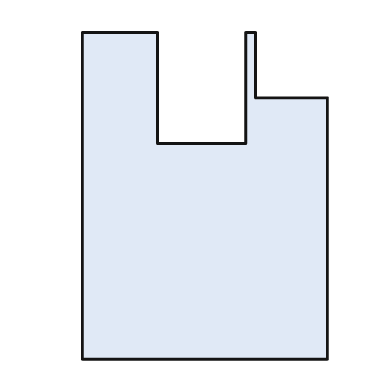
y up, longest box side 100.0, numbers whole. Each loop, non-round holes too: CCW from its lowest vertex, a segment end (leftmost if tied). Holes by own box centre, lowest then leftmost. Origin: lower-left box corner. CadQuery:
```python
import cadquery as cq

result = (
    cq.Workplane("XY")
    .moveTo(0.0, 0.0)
    .lineTo(75.0, 0.0)
    .lineTo(75.0, 80.0)
    .lineTo(53.0, 80.0)
    .lineTo(53.0, 100.0)
    .lineTo(50.0, 100.0)
    .lineTo(50.0, 66.0)
    .lineTo(23.0, 66.0)
    .lineTo(23.0, 100.0)
    .lineTo(0.0, 100.0)
    .close()
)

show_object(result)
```